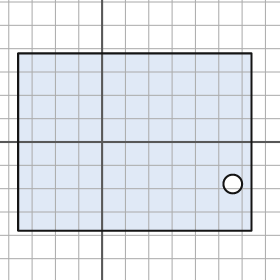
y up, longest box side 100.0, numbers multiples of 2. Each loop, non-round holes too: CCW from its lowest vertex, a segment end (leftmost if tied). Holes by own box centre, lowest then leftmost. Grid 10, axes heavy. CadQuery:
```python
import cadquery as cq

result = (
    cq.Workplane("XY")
    .moveTo(-36.0, -38.0)
    .lineTo(64.0, -38.0)
    .lineTo(64.0, 38.0)
    .lineTo(-36.0, 38.0)
    .close()
    .moveTo(56.0, -18.0)
    .circle(4.0)
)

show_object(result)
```